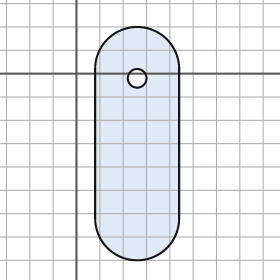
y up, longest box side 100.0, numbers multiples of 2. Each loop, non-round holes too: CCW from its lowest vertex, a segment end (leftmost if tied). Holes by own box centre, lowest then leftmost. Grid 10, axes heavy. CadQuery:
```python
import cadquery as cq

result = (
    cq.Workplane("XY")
    .moveTo(8.0, -62.0)
    .threePointArc((26.0, -80.0), (44.0, -62.0))
    .lineTo(44.0, 2.0)
    .threePointArc((26.0, 20.0), (8.0, 2.0))
    .close()
    .moveTo(26.0, -2.0)
    .circle(4.0)
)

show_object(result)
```